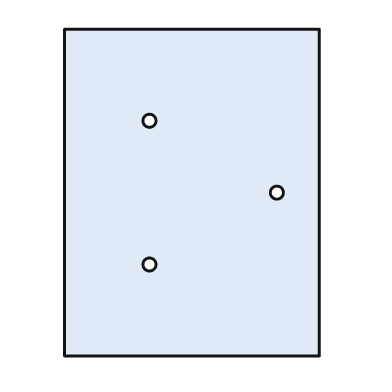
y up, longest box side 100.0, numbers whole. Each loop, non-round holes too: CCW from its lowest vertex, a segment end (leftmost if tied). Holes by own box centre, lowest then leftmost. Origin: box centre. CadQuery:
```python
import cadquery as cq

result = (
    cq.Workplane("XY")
    .moveTo(-39.0, -50.0)
    .lineTo(39.0, -50.0)
    .lineTo(39.0, 50.0)
    .lineTo(-39.0, 50.0)
    .close()
    .moveTo(-13.0, -22.0)
    .circle(2.0)
    .moveTo(26.0, 0.0)
    .circle(2.0)
    .moveTo(-13.0, 22.0)
    .circle(2.0)
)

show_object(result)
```